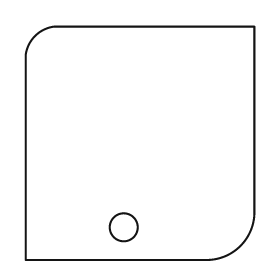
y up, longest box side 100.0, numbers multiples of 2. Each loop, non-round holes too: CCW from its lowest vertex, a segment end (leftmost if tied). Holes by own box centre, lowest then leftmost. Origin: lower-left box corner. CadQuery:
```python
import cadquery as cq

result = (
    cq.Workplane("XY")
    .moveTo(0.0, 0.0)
    .lineTo(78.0, 0.0)
    .threePointArc((92.0, 6.0), (98.0, 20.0))
    .lineTo(98.0, 100.0)
    .lineTo(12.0, 100.0)
    .threePointArc((4.0, 96.0), (0.0, 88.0))
    .close()
    .moveTo(42.0, 14.0)
    .circle(6.0)
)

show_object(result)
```